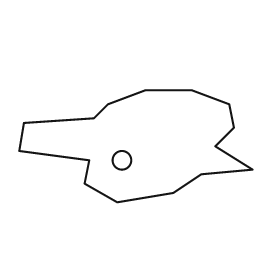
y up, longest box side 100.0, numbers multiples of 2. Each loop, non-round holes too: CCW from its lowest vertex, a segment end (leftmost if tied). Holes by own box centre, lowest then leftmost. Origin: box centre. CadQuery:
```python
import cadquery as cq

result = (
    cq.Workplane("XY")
    .moveTo(-8.0, -24.0)
    .lineTo(16.0, -20.0)
    .lineTo(28.0, -12.0)
    .lineTo(50.0, -10.0)
    .lineTo(34.0, 0.0)
    .lineTo(42.0, 8.0)
    .lineTo(40.0, 18.0)
    .lineTo(24.0, 24.0)
    .lineTo(4.0, 24.0)
    .lineTo(-12.0, 18.0)
    .lineTo(-18.0, 12.0)
    .lineTo(-48.0, 10.0)
    .lineTo(-50.0, -2.0)
    .lineTo(-20.0, -6.0)
    .lineTo(-22.0, -16.0)
    .close()
    .moveTo(-6.0, -6.0)
    .circle(4.0)
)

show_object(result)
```